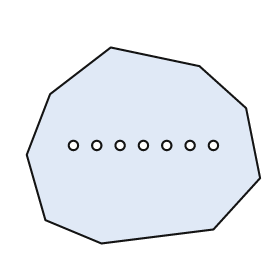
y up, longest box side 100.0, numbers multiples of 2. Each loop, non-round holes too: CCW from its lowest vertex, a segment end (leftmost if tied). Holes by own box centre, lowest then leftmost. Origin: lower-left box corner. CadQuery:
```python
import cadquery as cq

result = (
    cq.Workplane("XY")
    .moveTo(32.0, 0.0)
    .lineTo(80.0, 6.0)
    .lineTo(100.0, 28.0)
    .lineTo(94.0, 58.0)
    .lineTo(74.0, 76.0)
    .lineTo(36.0, 84.0)
    .lineTo(10.0, 64.0)
    .lineTo(0.0, 38.0)
    .lineTo(8.0, 10.0)
    .close()
    .moveTo(20.0, 42.0)
    .circle(2.0)
    .moveTo(30.0, 42.0)
    .circle(2.0)
    .moveTo(40.0, 42.0)
    .circle(2.0)
    .moveTo(50.0, 42.0)
    .circle(2.0)
    .moveTo(60.0, 42.0)
    .circle(2.0)
    .moveTo(70.0, 42.0)
    .circle(2.0)
    .moveTo(80.0, 42.0)
    .circle(2.0)
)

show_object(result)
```